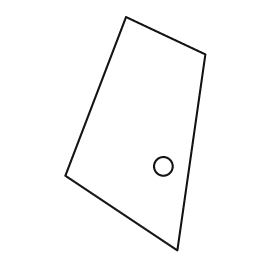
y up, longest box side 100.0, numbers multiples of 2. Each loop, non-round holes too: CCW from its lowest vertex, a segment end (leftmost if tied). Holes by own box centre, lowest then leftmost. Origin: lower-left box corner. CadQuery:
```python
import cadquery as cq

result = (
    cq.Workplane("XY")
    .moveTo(48.0, 0.0)
    .lineTo(60.0, 84.0)
    .lineTo(26.0, 100.0)
    .lineTo(0.0, 32.0)
    .close()
    .moveTo(42.0, 36.0)
    .circle(4.0)
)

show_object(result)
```